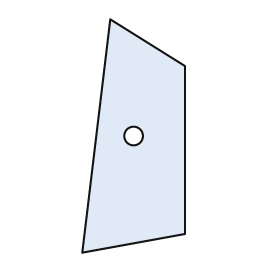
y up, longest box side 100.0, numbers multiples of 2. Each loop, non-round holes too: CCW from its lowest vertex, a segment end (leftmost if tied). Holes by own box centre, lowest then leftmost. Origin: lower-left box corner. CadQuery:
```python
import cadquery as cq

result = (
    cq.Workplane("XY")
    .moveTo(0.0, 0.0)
    .lineTo(44.0, 8.0)
    .lineTo(44.0, 80.0)
    .lineTo(12.0, 100.0)
    .close()
    .moveTo(22.0, 50.0)
    .circle(4.0)
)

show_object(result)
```